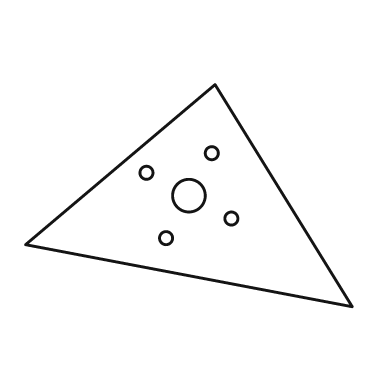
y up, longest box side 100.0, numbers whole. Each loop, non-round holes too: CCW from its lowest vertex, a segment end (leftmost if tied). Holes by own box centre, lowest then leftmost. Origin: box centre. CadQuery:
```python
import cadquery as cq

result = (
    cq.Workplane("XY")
    .moveTo(50.0, -34.0)
    .lineTo(8.0, 34.0)
    .lineTo(-50.0, -15.0)
    .close()
    .moveTo(-7.0, -13.0)
    .circle(2.0)
    .moveTo(13.0, -7.0)
    .circle(2.0)
    .moveTo(0.0, 0.0)
    .circle(5.0)
    .moveTo(-13.0, 7.0)
    .circle(2.0)
    .moveTo(7.0, 13.0)
    .circle(2.0)
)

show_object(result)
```